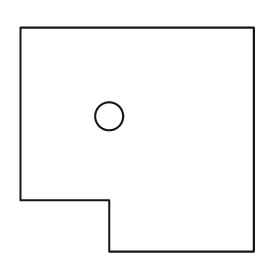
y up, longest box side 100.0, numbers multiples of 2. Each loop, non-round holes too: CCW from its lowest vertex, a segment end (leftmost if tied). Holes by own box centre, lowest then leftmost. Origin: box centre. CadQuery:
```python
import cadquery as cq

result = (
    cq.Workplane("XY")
    .moveTo(-12.0, -48.0)
    .lineTo(50.0, -48.0)
    .lineTo(50.0, 48.0)
    .lineTo(-50.0, 48.0)
    .lineTo(-50.0, -26.0)
    .lineTo(-12.0, -26.0)
    .close()
    .moveTo(-12.0, 10.0)
    .circle(6.0)
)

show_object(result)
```